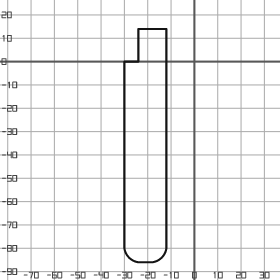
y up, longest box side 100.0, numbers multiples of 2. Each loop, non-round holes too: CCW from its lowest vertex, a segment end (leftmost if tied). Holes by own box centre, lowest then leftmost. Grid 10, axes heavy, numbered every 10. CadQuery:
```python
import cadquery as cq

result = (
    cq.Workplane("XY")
    .moveTo(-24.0, -86.0)
    .lineTo(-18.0, -86.0)
    .threePointArc((-14.0, -84.0), (-12.0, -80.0))
    .lineTo(-12.0, 14.0)
    .lineTo(-24.0, 14.0)
    .lineTo(-24.0, 0.0)
    .lineTo(-30.0, 0.0)
    .lineTo(-30.0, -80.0)
    .threePointArc((-28.0, -84.0), (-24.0, -86.0))
    .close()
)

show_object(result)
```